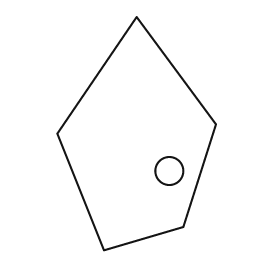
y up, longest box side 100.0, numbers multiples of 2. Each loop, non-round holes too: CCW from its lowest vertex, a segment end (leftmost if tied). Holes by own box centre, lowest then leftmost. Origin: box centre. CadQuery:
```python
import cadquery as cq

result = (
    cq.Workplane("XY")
    .moveTo(-14.0, -50.0)
    .lineTo(20.0, -40.0)
    .lineTo(34.0, 4.0)
    .lineTo(0.0, 50.0)
    .lineTo(-34.0, 0.0)
    .close()
    .moveTo(14.0, -16.0)
    .circle(6.0)
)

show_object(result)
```